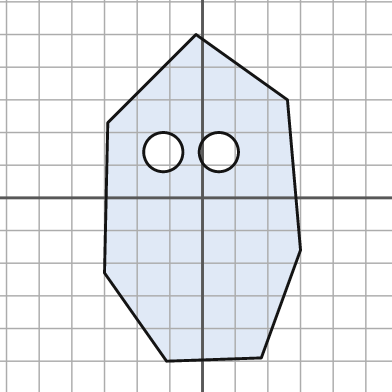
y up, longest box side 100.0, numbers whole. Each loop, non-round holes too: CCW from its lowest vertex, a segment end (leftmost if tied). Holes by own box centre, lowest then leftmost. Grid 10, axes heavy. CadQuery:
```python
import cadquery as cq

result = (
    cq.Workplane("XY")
    .moveTo(-11.0, -50.0)
    .lineTo(18.0, -49.0)
    .lineTo(30.0, -16.0)
    .lineTo(26.0, 30.0)
    .lineTo(-2.0, 50.0)
    .lineTo(-29.0, 23.0)
    .lineTo(-30.0, -23.0)
    .close()
    .moveTo(-12.0, 14.0)
    .circle(6.0)
    .moveTo(5.0, 14.0)
    .circle(6.0)
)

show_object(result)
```